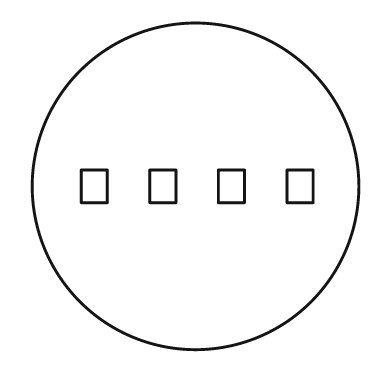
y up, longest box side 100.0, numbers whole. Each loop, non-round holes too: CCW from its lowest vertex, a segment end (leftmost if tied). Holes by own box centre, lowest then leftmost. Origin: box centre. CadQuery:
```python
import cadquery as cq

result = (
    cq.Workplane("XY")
    .moveTo(0.0, 0.0)
    .circle(50.0)
    .moveTo(-35.0, -5.0)
    .lineTo(-27.0, -5.0)
    .lineTo(-27.0, 5.0)
    .lineTo(-35.0, 5.0)
    .close()
    .moveTo(-14.0, -5.0)
    .lineTo(-6.0, -5.0)
    .lineTo(-6.0, 5.0)
    .lineTo(-14.0, 5.0)
    .close()
    .moveTo(7.0, -5.0)
    .lineTo(15.0, -5.0)
    .lineTo(15.0, 5.0)
    .lineTo(7.0, 5.0)
    .close()
    .moveTo(28.0, -5.0)
    .lineTo(36.0, -5.0)
    .lineTo(36.0, 5.0)
    .lineTo(28.0, 5.0)
    .close()
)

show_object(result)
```